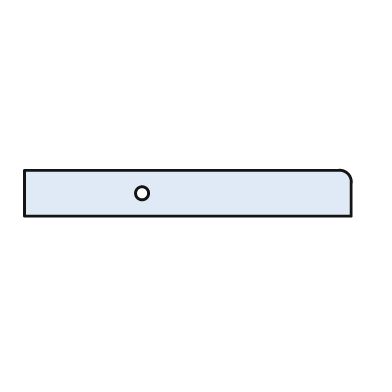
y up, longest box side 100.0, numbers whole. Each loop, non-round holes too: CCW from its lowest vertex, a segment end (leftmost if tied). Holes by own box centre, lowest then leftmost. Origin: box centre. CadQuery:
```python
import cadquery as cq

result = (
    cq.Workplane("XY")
    .moveTo(-50.0, -7.0)
    .lineTo(50.0, -7.0)
    .lineTo(50.0, 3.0)
    .threePointArc((49.0, 6.0), (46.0, 7.0))
    .lineTo(-50.0, 7.0)
    .close()
    .moveTo(-14.0, 0.0)
    .circle(2.0)
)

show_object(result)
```